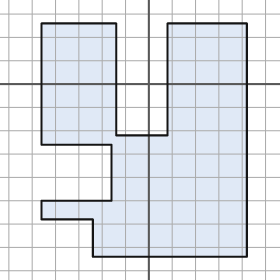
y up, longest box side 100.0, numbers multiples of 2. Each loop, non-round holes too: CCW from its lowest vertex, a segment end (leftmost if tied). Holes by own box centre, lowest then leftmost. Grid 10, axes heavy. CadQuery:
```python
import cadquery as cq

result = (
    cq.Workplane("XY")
    .moveTo(-24.0, -74.0)
    .lineTo(42.0, -74.0)
    .lineTo(42.0, 26.0)
    .lineTo(8.0, 26.0)
    .lineTo(8.0, -22.0)
    .lineTo(-14.0, -22.0)
    .lineTo(-14.0, 26.0)
    .lineTo(-46.0, 26.0)
    .lineTo(-46.0, -26.0)
    .lineTo(-16.0, -26.0)
    .lineTo(-16.0, -50.0)
    .lineTo(-46.0, -50.0)
    .lineTo(-46.0, -58.0)
    .lineTo(-24.0, -58.0)
    .close()
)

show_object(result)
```